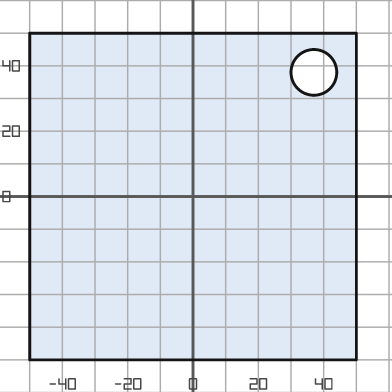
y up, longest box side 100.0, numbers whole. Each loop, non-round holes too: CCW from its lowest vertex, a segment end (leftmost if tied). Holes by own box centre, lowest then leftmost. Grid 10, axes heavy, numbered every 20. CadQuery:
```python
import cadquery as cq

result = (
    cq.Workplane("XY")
    .moveTo(-50.0, -50.0)
    .lineTo(50.0, -50.0)
    .lineTo(50.0, 50.0)
    .lineTo(-50.0, 50.0)
    .close()
    .moveTo(37.0, 38.0)
    .circle(7.0)
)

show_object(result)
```